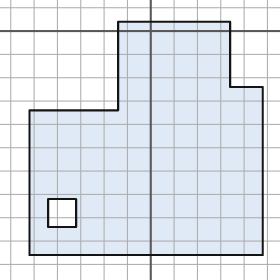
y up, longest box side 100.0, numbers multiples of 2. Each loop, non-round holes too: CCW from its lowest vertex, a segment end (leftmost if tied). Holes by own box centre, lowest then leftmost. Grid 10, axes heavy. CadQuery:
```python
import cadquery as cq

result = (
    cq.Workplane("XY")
    .moveTo(-52.0, -96.0)
    .lineTo(48.0, -96.0)
    .lineTo(48.0, -24.0)
    .lineTo(34.0, -24.0)
    .lineTo(34.0, 4.0)
    .lineTo(-14.0, 4.0)
    .lineTo(-14.0, -34.0)
    .lineTo(-52.0, -34.0)
    .close()
    .moveTo(-44.0, -84.0)
    .lineTo(-32.0, -84.0)
    .lineTo(-32.0, -72.0)
    .lineTo(-44.0, -72.0)
    .close()
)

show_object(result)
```